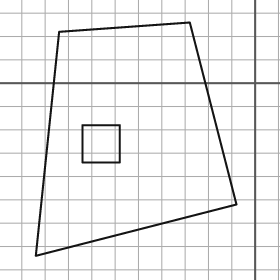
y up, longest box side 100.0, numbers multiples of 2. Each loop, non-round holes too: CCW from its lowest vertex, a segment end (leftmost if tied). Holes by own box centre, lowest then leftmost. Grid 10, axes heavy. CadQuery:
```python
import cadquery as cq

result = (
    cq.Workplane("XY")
    .moveTo(-94.0, -74.0)
    .lineTo(-8.0, -52.0)
    .lineTo(-28.0, 26.0)
    .lineTo(-84.0, 22.0)
    .close()
    .moveTo(-74.0, -34.0)
    .lineTo(-58.0, -34.0)
    .lineTo(-58.0, -18.0)
    .lineTo(-74.0, -18.0)
    .close()
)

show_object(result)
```